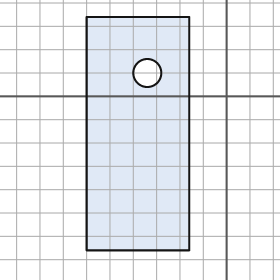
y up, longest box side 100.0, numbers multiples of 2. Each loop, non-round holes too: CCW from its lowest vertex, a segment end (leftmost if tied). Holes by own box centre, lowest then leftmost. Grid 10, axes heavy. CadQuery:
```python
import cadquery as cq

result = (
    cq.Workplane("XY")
    .moveTo(-60.0, -66.0)
    .lineTo(-16.0, -66.0)
    .lineTo(-16.0, 34.0)
    .lineTo(-60.0, 34.0)
    .close()
    .moveTo(-34.0, 10.0)
    .circle(6.0)
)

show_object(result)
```